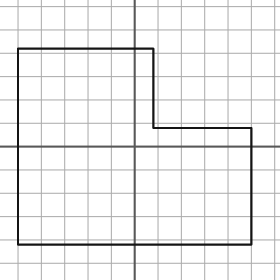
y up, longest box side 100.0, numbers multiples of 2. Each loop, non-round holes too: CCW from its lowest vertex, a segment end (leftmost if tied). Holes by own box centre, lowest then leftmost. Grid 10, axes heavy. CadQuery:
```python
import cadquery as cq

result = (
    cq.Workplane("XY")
    .moveTo(-50.0, -42.0)
    .lineTo(50.0, -42.0)
    .lineTo(50.0, 8.0)
    .lineTo(8.0, 8.0)
    .lineTo(8.0, 42.0)
    .lineTo(-50.0, 42.0)
    .close()
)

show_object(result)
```